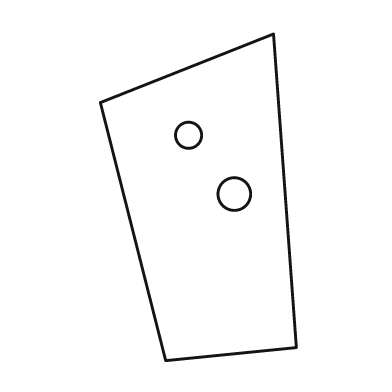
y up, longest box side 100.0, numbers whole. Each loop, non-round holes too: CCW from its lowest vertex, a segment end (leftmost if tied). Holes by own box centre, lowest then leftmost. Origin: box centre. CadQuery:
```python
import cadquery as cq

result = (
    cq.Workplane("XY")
    .moveTo(-10.0, -50.0)
    .lineTo(30.0, -46.0)
    .lineTo(23.0, 50.0)
    .lineTo(-30.0, 29.0)
    .close()
    .moveTo(11.0, 1.0)
    .circle(5.0)
    .moveTo(-3.0, 19.0)
    .circle(4.0)
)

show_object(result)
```